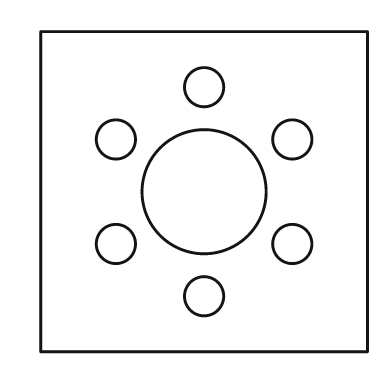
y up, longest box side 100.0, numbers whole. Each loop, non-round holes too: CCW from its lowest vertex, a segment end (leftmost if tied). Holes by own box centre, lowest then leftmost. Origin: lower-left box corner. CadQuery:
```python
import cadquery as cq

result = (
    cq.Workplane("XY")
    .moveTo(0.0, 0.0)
    .lineTo(100.0, 0.0)
    .lineTo(100.0, 98.0)
    .lineTo(0.0, 98.0)
    .close()
    .moveTo(50.0, 17.0)
    .circle(6.0)
    .moveTo(23.0, 33.0)
    .circle(6.0)
    .moveTo(77.0, 33.0)
    .circle(6.0)
    .moveTo(50.0, 49.0)
    .circle(19.0)
    .moveTo(23.0, 65.0)
    .circle(6.0)
    .moveTo(77.0, 65.0)
    .circle(6.0)
    .moveTo(50.0, 81.0)
    .circle(6.0)
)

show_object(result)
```